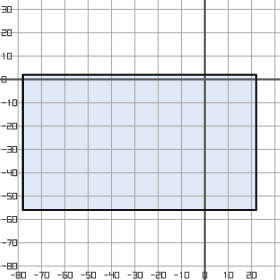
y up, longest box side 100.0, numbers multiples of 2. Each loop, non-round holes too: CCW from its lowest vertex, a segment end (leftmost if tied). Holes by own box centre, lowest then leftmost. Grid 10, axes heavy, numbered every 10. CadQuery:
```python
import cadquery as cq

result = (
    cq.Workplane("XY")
    .moveTo(-78.0, -56.0)
    .lineTo(22.0, -56.0)
    .lineTo(22.0, 2.0)
    .lineTo(-78.0, 2.0)
    .close()
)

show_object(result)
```